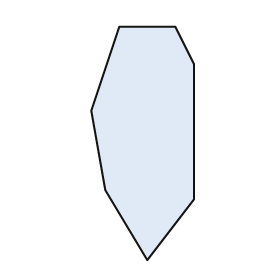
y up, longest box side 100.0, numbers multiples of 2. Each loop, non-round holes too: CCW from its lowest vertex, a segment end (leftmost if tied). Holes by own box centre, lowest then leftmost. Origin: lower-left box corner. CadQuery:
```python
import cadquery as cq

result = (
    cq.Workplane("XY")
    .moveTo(24.0, 0.0)
    .lineTo(44.0, 26.0)
    .lineTo(44.0, 84.0)
    .lineTo(36.0, 100.0)
    .lineTo(12.0, 100.0)
    .lineTo(0.0, 64.0)
    .lineTo(6.0, 30.0)
    .close()
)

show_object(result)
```